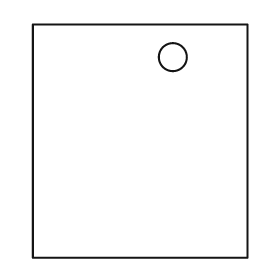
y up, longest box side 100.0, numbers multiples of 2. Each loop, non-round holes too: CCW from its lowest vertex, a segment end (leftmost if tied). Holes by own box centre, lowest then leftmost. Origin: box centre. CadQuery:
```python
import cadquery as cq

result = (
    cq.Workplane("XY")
    .moveTo(-46.0, -50.0)
    .lineTo(46.0, -50.0)
    .lineTo(46.0, 50.0)
    .lineTo(-46.0, 50.0)
    .close()
    .moveTo(14.0, 36.0)
    .circle(6.0)
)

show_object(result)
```